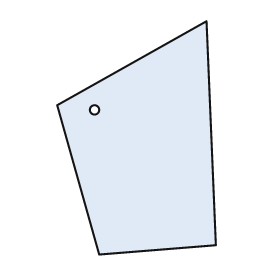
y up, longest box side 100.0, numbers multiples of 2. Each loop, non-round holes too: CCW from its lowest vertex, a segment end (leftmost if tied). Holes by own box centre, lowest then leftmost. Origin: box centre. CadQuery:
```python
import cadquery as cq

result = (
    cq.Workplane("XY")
    .moveTo(-16.0, -50.0)
    .lineTo(34.0, -46.0)
    .lineTo(30.0, 50.0)
    .lineTo(-34.0, 14.0)
    .close()
    .moveTo(-18.0, 12.0)
    .circle(2.0)
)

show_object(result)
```